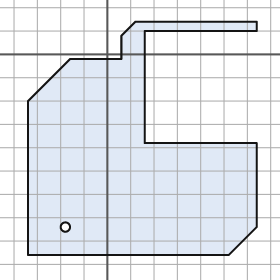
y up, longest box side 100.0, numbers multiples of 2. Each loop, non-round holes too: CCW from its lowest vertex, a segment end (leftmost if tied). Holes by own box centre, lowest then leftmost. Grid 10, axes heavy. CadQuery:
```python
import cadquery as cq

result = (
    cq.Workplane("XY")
    .moveTo(-34.0, -86.0)
    .lineTo(52.0, -86.0)
    .lineTo(64.0, -74.0)
    .lineTo(64.0, -38.0)
    .lineTo(16.0, -38.0)
    .lineTo(16.0, 10.0)
    .lineTo(64.0, 10.0)
    .lineTo(64.0, 14.0)
    .lineTo(12.0, 14.0)
    .lineTo(6.0, 8.0)
    .lineTo(6.0, -2.0)
    .lineTo(-16.0, -2.0)
    .lineTo(-34.0, -20.0)
    .close()
    .moveTo(-18.0, -74.0)
    .circle(2.0)
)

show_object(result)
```